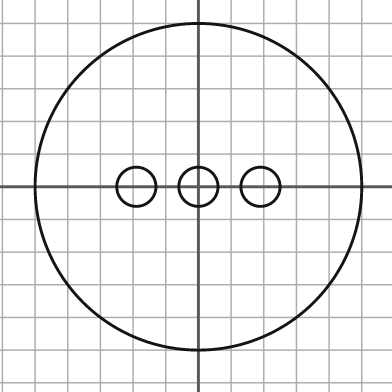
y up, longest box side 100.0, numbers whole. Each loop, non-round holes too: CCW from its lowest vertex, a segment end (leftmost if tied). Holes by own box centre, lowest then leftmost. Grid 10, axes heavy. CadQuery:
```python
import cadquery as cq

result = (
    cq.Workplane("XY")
    .moveTo(0.0, 0.0)
    .circle(50.0)
    .moveTo(-19.0, 0.0)
    .circle(6.0)
    .moveTo(0.0, 0.0)
    .circle(6.0)
    .moveTo(19.0, 0.0)
    .circle(6.0)
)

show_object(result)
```